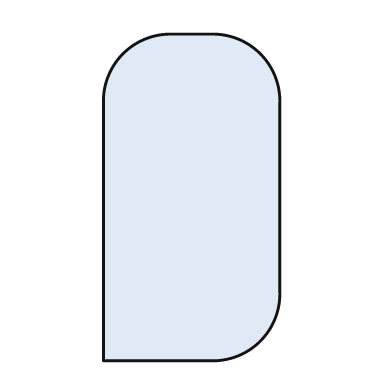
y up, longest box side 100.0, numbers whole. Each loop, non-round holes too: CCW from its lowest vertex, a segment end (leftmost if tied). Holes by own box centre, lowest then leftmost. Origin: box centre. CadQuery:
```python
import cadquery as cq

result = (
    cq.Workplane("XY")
    .moveTo(-27.0, -50.0)
    .lineTo(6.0, -50.0)
    .threePointArc((21.0, -44.0), (27.0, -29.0))
    .lineTo(27.0, 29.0)
    .threePointArc((21.0, 44.0), (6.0, 50.0))
    .lineTo(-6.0, 50.0)
    .threePointArc((-21.0, 44.0), (-27.0, 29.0))
    .close()
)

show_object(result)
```